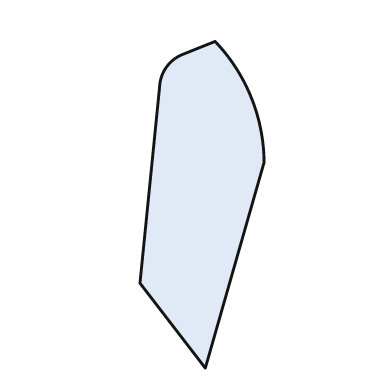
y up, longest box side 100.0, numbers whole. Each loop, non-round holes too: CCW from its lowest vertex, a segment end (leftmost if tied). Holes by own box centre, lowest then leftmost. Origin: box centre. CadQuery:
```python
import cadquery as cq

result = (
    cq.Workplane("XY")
    .moveTo(1.0, -50.0)
    .lineTo(19.0, 13.0)
    .threePointArc((15.0, 33.0), (4.0, 50.0))
    .lineTo(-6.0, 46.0)
    .threePointArc((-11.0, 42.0), (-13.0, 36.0))
    .lineTo(-19.0, -24.0)
    .close()
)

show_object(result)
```